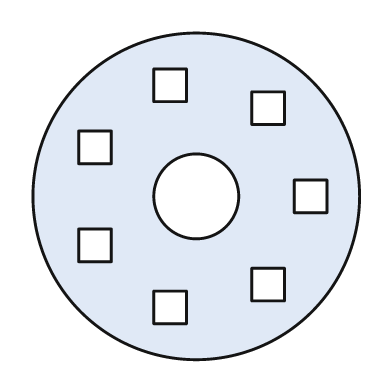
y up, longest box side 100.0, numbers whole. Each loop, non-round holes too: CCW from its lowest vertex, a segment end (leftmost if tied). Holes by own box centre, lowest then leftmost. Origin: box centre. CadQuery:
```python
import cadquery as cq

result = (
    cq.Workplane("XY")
    .moveTo(0.0, 0.0)
    .circle(50.0)
    .moveTo(-13.0, -39.0)
    .lineTo(-3.0, -39.0)
    .lineTo(-3.0, -29.0)
    .lineTo(-13.0, -29.0)
    .close()
    .moveTo(17.0, -32.0)
    .lineTo(27.0, -32.0)
    .lineTo(27.0, -22.0)
    .lineTo(17.0, -22.0)
    .close()
    .moveTo(-36.0, -20.0)
    .lineTo(-26.0, -20.0)
    .lineTo(-26.0, -10.0)
    .lineTo(-36.0, -10.0)
    .close()
    .moveTo(0.0, 0.0)
    .circle(13.0)
    .moveTo(30.0, -5.0)
    .lineTo(40.0, -5.0)
    .lineTo(40.0, 5.0)
    .lineTo(30.0, 5.0)
    .close()
    .moveTo(-36.0, 10.0)
    .lineTo(-26.0, 10.0)
    .lineTo(-26.0, 20.0)
    .lineTo(-36.0, 20.0)
    .close()
    .moveTo(17.0, 22.0)
    .lineTo(27.0, 22.0)
    .lineTo(27.0, 32.0)
    .lineTo(17.0, 32.0)
    .close()
    .moveTo(-13.0, 29.0)
    .lineTo(-3.0, 29.0)
    .lineTo(-3.0, 39.0)
    .lineTo(-13.0, 39.0)
    .close()
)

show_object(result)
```